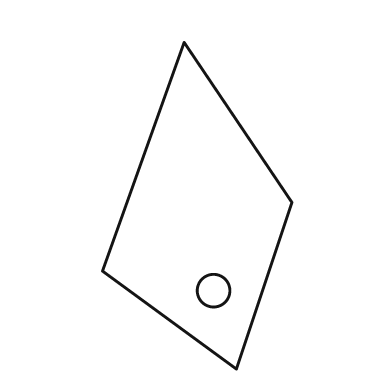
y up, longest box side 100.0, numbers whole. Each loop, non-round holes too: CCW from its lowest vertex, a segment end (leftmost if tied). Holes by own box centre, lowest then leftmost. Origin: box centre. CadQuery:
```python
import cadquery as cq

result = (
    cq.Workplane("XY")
    .moveTo(12.0, -50.0)
    .lineTo(29.0, 1.0)
    .lineTo(-4.0, 50.0)
    .lineTo(-29.0, -20.0)
    .close()
    .moveTo(5.0, -26.0)
    .circle(5.0)
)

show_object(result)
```